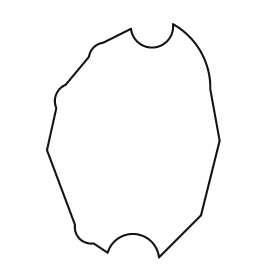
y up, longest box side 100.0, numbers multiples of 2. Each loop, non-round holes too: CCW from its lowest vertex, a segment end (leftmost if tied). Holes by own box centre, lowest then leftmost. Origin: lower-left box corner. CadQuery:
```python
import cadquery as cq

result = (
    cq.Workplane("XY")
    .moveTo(48.0, 0.0)
    .lineTo(66.0, 18.0)
    .lineTo(74.0, 50.0)
    .lineTo(70.0, 72.0)
    .threePointArc((66.0, 88.0), (54.0, 100.0))
    .threePointArc((46.0, 90.0), (36.0, 98.0))
    .lineTo(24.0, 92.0)
    .threePointArc((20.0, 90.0), (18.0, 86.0))
    .lineTo(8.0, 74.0)
    .threePointArc((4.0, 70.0), (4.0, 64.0))
    .lineTo(0.0, 46.0)
    .lineTo(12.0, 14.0)
    .threePointArc((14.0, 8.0), (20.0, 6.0))
    .lineTo(26.0, 2.0)
    .threePointArc((38.0, 10.0), (48.0, 0.0))
    .close()
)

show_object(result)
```